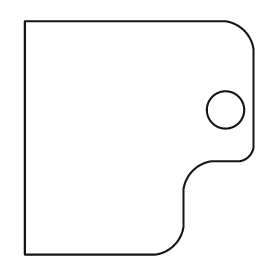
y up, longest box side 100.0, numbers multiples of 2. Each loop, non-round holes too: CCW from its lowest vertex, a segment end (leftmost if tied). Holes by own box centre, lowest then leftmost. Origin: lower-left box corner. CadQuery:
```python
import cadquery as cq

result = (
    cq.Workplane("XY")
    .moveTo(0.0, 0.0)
    .lineTo(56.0, 0.0)
    .threePointArc((64.0, 4.0), (68.0, 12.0))
    .lineTo(68.0, 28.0)
    .threePointArc((72.0, 36.0), (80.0, 40.0))
    .lineTo(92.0, 40.0)
    .threePointArc((96.0, 42.0), (98.0, 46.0))
    .lineTo(98.0, 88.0)
    .threePointArc((94.0, 96.0), (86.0, 100.0))
    .lineTo(0.0, 100.0)
    .close()
    .moveTo(86.0, 62.0)
    .circle(8.0)
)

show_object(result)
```